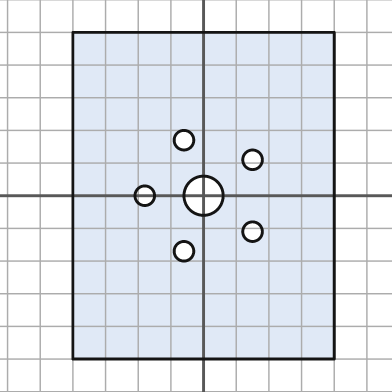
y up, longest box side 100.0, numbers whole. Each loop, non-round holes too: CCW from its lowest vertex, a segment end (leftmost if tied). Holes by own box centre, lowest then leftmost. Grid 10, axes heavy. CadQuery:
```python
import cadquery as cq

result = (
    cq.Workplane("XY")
    .moveTo(-40.0, -50.0)
    .lineTo(40.0, -50.0)
    .lineTo(40.0, 50.0)
    .lineTo(-40.0, 50.0)
    .close()
    .moveTo(-6.0, -17.0)
    .circle(3.0)
    .moveTo(15.0, -11.0)
    .circle(3.0)
    .moveTo(-18.0, 0.0)
    .circle(3.0)
    .moveTo(0.0, 0.0)
    .circle(6.0)
    .moveTo(15.0, 11.0)
    .circle(3.0)
    .moveTo(-6.0, 17.0)
    .circle(3.0)
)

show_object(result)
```